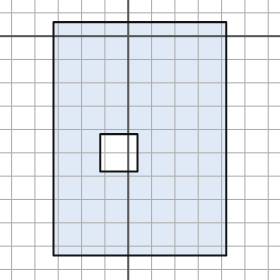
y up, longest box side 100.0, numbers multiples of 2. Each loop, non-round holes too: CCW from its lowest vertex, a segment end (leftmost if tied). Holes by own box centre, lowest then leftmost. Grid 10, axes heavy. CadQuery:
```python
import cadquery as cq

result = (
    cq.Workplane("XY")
    .moveTo(-32.0, -94.0)
    .lineTo(42.0, -94.0)
    .lineTo(42.0, 6.0)
    .lineTo(-32.0, 6.0)
    .close()
    .moveTo(-12.0, -58.0)
    .lineTo(4.0, -58.0)
    .lineTo(4.0, -42.0)
    .lineTo(-12.0, -42.0)
    .close()
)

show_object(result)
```